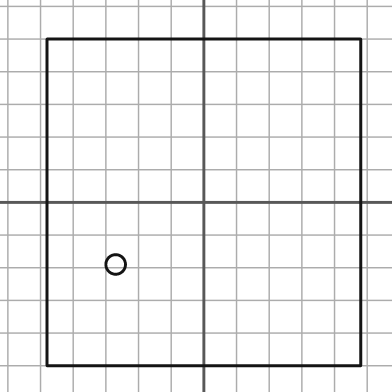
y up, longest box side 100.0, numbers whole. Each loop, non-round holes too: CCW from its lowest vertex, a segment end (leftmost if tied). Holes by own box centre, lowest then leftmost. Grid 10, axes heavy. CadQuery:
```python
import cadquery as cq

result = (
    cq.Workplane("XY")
    .moveTo(-48.0, -50.0)
    .lineTo(48.0, -50.0)
    .lineTo(48.0, 50.0)
    .lineTo(-48.0, 50.0)
    .close()
    .moveTo(-27.0, -19.0)
    .circle(3.0)
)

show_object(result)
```